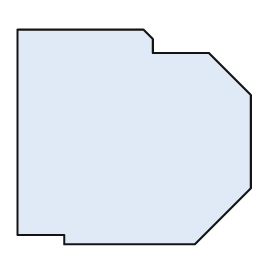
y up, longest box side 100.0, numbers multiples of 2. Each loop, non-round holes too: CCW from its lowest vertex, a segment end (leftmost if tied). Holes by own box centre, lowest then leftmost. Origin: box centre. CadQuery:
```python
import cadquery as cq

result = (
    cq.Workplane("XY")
    .moveTo(-30.0, -46.0)
    .lineTo(26.0, -46.0)
    .lineTo(50.0, -22.0)
    .lineTo(50.0, 18.0)
    .lineTo(32.0, 36.0)
    .lineTo(8.0, 36.0)
    .lineTo(8.0, 42.0)
    .lineTo(4.0, 46.0)
    .lineTo(-50.0, 46.0)
    .lineTo(-50.0, -42.0)
    .lineTo(-30.0, -42.0)
    .close()
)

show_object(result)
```